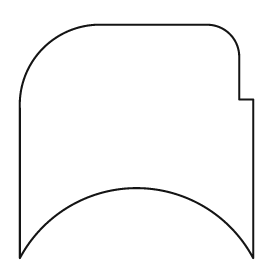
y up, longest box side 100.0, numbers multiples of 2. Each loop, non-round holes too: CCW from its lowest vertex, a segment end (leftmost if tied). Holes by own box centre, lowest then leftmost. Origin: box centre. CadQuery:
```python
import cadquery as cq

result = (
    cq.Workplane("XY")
    .moveTo(-50.0, -50.0)
    .threePointArc((0.0, -20.0), (50.0, -50.0))
    .lineTo(50.0, 18.0)
    .lineTo(44.0, 18.0)
    .lineTo(44.0, 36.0)
    .threePointArc((40.0, 46.0), (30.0, 50.0))
    .lineTo(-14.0, 50.0)
    .threePointArc((-40.0, 40.0), (-50.0, 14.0))
    .close()
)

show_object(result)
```